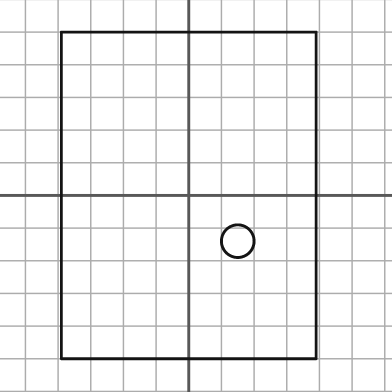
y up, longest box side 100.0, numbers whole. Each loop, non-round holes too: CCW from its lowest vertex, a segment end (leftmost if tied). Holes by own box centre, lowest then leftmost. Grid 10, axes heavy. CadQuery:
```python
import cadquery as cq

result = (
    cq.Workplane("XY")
    .moveTo(-39.0, -50.0)
    .lineTo(39.0, -50.0)
    .lineTo(39.0, 50.0)
    .lineTo(-39.0, 50.0)
    .close()
    .moveTo(15.0, -14.0)
    .circle(5.0)
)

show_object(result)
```